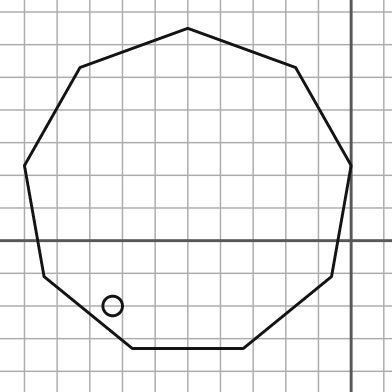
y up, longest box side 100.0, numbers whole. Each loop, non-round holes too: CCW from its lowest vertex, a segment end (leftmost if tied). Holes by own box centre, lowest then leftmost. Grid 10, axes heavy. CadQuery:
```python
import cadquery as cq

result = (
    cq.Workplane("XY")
    .moveTo(-67.0, -33.0)
    .lineTo(-33.0, -33.0)
    .lineTo(-6.0, -11.0)
    .lineTo(0.0, 23.0)
    .lineTo(-17.0, 53.0)
    .lineTo(-50.0, 65.0)
    .lineTo(-83.0, 53.0)
    .lineTo(-100.0, 23.0)
    .lineTo(-94.0, -11.0)
    .close()
    .moveTo(-73.0, -20.0)
    .circle(3.0)
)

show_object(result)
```